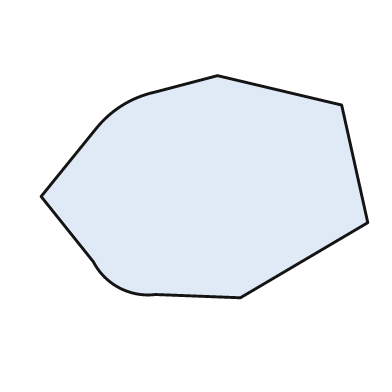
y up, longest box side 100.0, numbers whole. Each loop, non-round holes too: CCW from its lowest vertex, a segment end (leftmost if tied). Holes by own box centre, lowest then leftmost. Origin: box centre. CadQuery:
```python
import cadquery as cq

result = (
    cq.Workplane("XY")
    .moveTo(11.0, -34.0)
    .lineTo(50.0, -11.0)
    .lineTo(42.0, 25.0)
    .lineTo(4.0, 34.0)
    .lineTo(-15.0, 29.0)
    .threePointArc((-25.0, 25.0), (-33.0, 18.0))
    .lineTo(-50.0, -3.0)
    .lineTo(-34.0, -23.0)
    .threePointArc((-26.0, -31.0), (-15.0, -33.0))
    .close()
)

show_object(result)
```